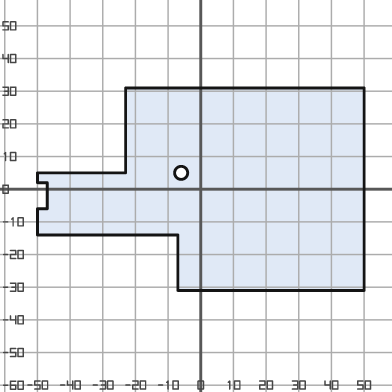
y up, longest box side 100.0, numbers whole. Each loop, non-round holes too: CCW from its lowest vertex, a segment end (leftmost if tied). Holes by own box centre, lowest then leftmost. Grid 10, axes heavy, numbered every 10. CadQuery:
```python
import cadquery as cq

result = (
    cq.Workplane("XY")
    .moveTo(-7.0, -31.0)
    .lineTo(50.0, -31.0)
    .lineTo(50.0, 31.0)
    .lineTo(-23.0, 31.0)
    .lineTo(-23.0, 5.0)
    .lineTo(-50.0, 5.0)
    .lineTo(-50.0, 2.0)
    .lineTo(-47.0, 2.0)
    .lineTo(-47.0, -6.0)
    .lineTo(-50.0, -6.0)
    .lineTo(-50.0, -14.0)
    .lineTo(-7.0, -14.0)
    .close()
    .moveTo(-6.0, 5.0)
    .circle(2.0)
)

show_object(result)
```